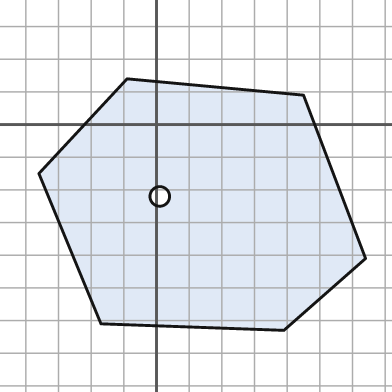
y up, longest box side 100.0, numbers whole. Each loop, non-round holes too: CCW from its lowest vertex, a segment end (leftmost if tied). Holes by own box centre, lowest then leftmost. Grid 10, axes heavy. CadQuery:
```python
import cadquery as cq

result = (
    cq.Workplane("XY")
    .moveTo(39.0, -63.0)
    .lineTo(64.0, -41.0)
    .lineTo(45.0, 9.0)
    .lineTo(-9.0, 14.0)
    .lineTo(-36.0, -15.0)
    .lineTo(-17.0, -61.0)
    .close()
    .moveTo(1.0, -22.0)
    .circle(3.0)
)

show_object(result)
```